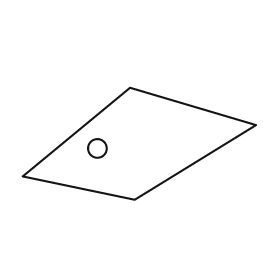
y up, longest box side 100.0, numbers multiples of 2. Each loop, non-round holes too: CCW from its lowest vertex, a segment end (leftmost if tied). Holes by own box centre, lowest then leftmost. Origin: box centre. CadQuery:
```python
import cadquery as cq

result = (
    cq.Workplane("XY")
    .moveTo(-2.0, -24.0)
    .lineTo(50.0, 8.0)
    .lineTo(-4.0, 24.0)
    .lineTo(-50.0, -14.0)
    .close()
    .moveTo(-18.0, -2.0)
    .circle(4.0)
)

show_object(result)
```